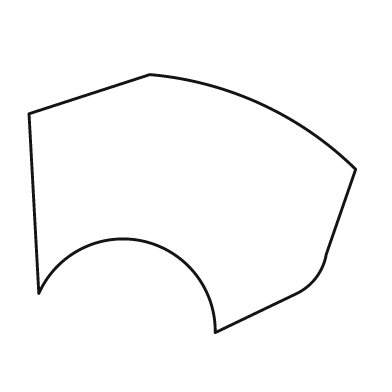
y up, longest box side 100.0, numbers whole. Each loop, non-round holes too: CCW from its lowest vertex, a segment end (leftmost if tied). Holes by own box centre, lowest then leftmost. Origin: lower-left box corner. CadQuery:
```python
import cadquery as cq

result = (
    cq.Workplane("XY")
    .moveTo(57.0, 0.0)
    .lineTo(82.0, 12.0)
    .threePointArc((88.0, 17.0), (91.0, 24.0))
    .lineTo(100.0, 50.0)
    .threePointArc((71.0, 70.0), (37.0, 79.0))
    .lineTo(0.0, 67.0)
    .lineTo(3.0, 12.0)
    .threePointArc((35.0, 28.0), (57.0, 0.0))
    .close()
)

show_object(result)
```